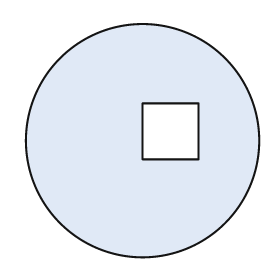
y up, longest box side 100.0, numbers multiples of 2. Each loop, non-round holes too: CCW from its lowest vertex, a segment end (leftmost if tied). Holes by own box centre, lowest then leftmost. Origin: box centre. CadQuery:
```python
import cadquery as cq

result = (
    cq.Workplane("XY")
    .moveTo(0.0, 0.0)
    .circle(50.0)
    .moveTo(0.0, -8.0)
    .lineTo(24.0, -8.0)
    .lineTo(24.0, 16.0)
    .lineTo(0.0, 16.0)
    .close()
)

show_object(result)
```